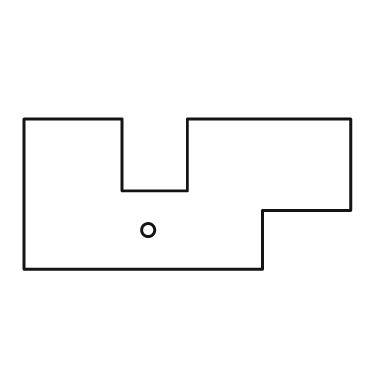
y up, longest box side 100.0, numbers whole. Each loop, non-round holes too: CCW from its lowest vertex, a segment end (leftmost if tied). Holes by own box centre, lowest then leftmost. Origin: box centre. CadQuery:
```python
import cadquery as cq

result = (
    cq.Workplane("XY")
    .moveTo(-50.0, -23.0)
    .lineTo(23.0, -23.0)
    .lineTo(23.0, -5.0)
    .lineTo(50.0, -5.0)
    .lineTo(50.0, 23.0)
    .lineTo(0.0, 23.0)
    .lineTo(0.0, 1.0)
    .lineTo(-20.0, 1.0)
    .lineTo(-20.0, 23.0)
    .lineTo(-50.0, 23.0)
    .close()
    .moveTo(-12.0, -11.0)
    .circle(2.0)
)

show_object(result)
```